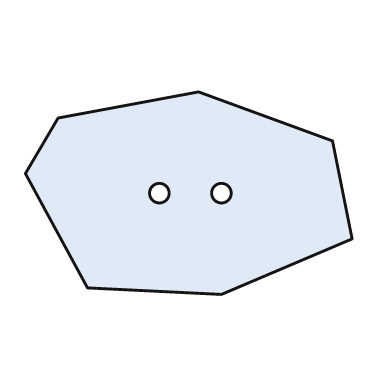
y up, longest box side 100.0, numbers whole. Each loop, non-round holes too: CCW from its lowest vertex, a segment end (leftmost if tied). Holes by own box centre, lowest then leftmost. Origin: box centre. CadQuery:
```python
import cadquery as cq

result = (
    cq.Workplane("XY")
    .moveTo(10.0, -31.0)
    .lineTo(50.0, -14.0)
    .lineTo(44.0, 16.0)
    .lineTo(3.0, 31.0)
    .lineTo(-40.0, 23.0)
    .lineTo(-50.0, 6.0)
    .lineTo(-31.0, -29.0)
    .close()
    .moveTo(-9.0, 0.0)
    .circle(3.0)
    .moveTo(10.0, 0.0)
    .circle(3.0)
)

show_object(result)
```